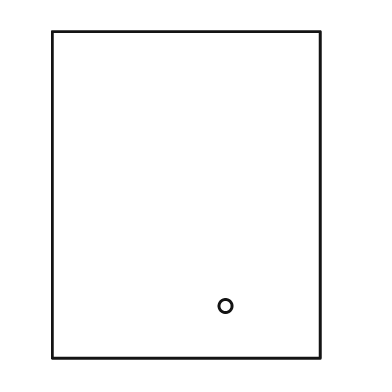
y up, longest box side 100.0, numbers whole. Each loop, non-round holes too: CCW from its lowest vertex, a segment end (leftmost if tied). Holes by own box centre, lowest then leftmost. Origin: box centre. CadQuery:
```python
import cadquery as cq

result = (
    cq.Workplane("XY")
    .moveTo(-41.0, -50.0)
    .lineTo(41.0, -50.0)
    .lineTo(41.0, 50.0)
    .lineTo(-41.0, 50.0)
    .close()
    .moveTo(12.0, -34.0)
    .circle(2.0)
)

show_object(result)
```